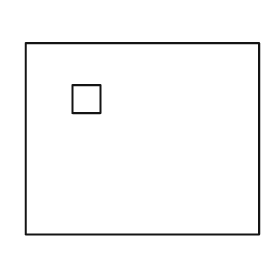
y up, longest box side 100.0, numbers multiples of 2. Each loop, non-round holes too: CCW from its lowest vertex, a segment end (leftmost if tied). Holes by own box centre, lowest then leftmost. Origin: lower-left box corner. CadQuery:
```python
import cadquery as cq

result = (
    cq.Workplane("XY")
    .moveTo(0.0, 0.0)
    .lineTo(100.0, 0.0)
    .lineTo(100.0, 82.0)
    .lineTo(0.0, 82.0)
    .close()
    .moveTo(20.0, 52.0)
    .lineTo(32.0, 52.0)
    .lineTo(32.0, 64.0)
    .lineTo(20.0, 64.0)
    .close()
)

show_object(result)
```